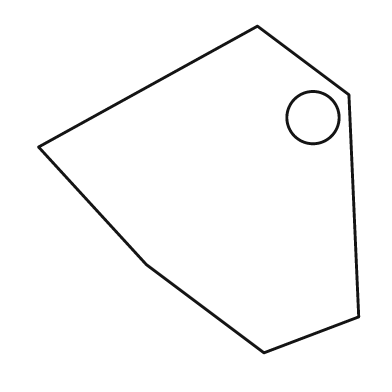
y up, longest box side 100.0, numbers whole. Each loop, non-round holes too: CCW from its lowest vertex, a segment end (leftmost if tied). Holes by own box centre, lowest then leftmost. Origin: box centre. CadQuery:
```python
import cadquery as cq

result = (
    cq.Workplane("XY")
    .moveTo(20.0, -50.0)
    .lineTo(49.0, -39.0)
    .lineTo(46.0, 29.0)
    .lineTo(18.0, 50.0)
    .lineTo(-49.0, 13.0)
    .lineTo(-16.0, -23.0)
    .close()
    .moveTo(35.0, 22.0)
    .circle(8.0)
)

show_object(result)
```